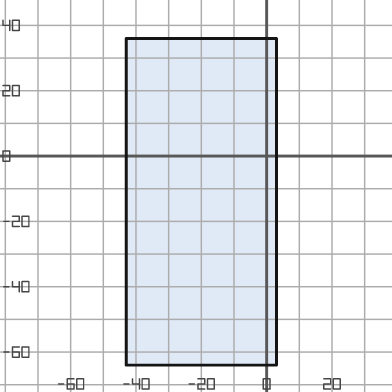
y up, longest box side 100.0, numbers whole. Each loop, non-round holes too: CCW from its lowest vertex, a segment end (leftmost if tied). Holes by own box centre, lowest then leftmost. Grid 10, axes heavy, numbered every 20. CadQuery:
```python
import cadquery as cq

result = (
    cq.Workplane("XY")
    .moveTo(-43.0, -64.0)
    .lineTo(3.0, -64.0)
    .lineTo(3.0, 36.0)
    .lineTo(-43.0, 36.0)
    .close()
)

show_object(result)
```